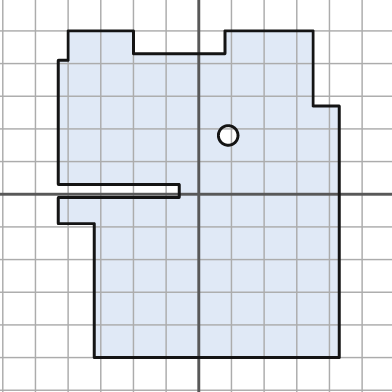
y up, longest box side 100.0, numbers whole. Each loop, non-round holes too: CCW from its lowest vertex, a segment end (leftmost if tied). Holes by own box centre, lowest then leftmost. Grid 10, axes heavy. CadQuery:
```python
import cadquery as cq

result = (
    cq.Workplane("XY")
    .moveTo(-32.0, -50.0)
    .lineTo(43.0, -50.0)
    .lineTo(43.0, 27.0)
    .lineTo(35.0, 27.0)
    .lineTo(35.0, 50.0)
    .lineTo(8.0, 50.0)
    .lineTo(8.0, 43.0)
    .lineTo(-20.0, 43.0)
    .lineTo(-20.0, 50.0)
    .lineTo(-40.0, 50.0)
    .lineTo(-40.0, 41.0)
    .lineTo(-43.0, 41.0)
    .lineTo(-43.0, 3.0)
    .lineTo(-6.0, 3.0)
    .lineTo(-6.0, -1.0)
    .lineTo(-43.0, -1.0)
    .lineTo(-43.0, -9.0)
    .lineTo(-32.0, -9.0)
    .close()
    .moveTo(9.0, 18.0)
    .circle(3.0)
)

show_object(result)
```